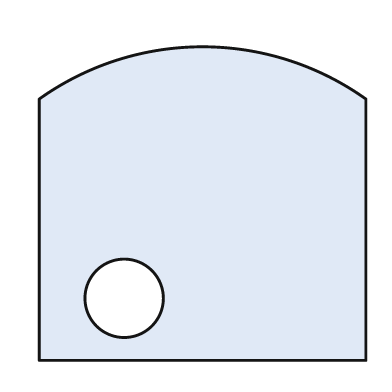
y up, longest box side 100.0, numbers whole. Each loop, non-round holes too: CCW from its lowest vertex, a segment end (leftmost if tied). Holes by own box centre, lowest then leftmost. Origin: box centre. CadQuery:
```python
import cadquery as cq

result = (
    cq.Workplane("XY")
    .moveTo(-50.0, -48.0)
    .lineTo(50.0, -48.0)
    .lineTo(50.0, 32.0)
    .threePointArc((0.0, 48.0), (-50.0, 32.0))
    .close()
    .moveTo(-24.0, -29.0)
    .circle(12.0)
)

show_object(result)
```